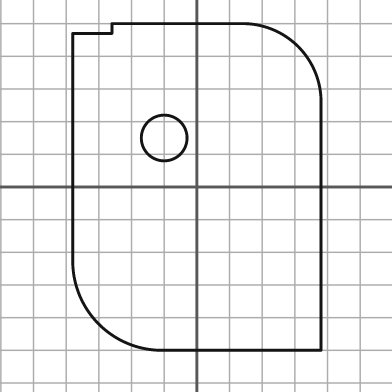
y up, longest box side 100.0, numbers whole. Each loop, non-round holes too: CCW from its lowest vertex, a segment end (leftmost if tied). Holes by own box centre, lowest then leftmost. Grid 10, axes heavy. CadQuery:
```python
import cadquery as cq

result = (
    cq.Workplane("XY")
    .moveTo(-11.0, -50.0)
    .lineTo(38.0, -50.0)
    .lineTo(38.0, 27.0)
    .threePointArc((31.0, 43.0), (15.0, 50.0))
    .lineTo(-26.0, 50.0)
    .lineTo(-26.0, 47.0)
    .lineTo(-38.0, 47.0)
    .lineTo(-38.0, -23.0)
    .threePointArc((-30.0, -42.0), (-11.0, -50.0))
    .close()
    .moveTo(-10.0, 15.0)
    .circle(7.0)
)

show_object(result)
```